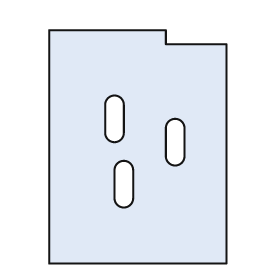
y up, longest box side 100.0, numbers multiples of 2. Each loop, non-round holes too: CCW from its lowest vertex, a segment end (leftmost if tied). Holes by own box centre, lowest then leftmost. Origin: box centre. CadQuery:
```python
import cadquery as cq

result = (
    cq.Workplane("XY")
    .moveTo(-38.0, -50.0)
    .lineTo(38.0, -50.0)
    .lineTo(38.0, 44.0)
    .lineTo(12.0, 44.0)
    .lineTo(12.0, 50.0)
    .lineTo(-38.0, 50.0)
    .close()
    .moveTo(-10.0, -22.0)
    .threePointArc((-6.0, -26.0), (-2.0, -22.0))
    .lineTo(-2.0, -10.0)
    .threePointArc((-6.0, -6.0), (-10.0, -10.0))
    .close()
    .moveTo(12.0, -4.0)
    .threePointArc((16.0, -8.0), (20.0, -4.0))
    .lineTo(20.0, 8.0)
    .threePointArc((16.0, 12.0), (12.0, 8.0))
    .close()
    .moveTo(-14.0, 6.0)
    .threePointArc((-10.0, 2.0), (-6.0, 6.0))
    .lineTo(-6.0, 18.0)
    .threePointArc((-10.0, 22.0), (-14.0, 18.0))
    .close()
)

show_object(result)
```